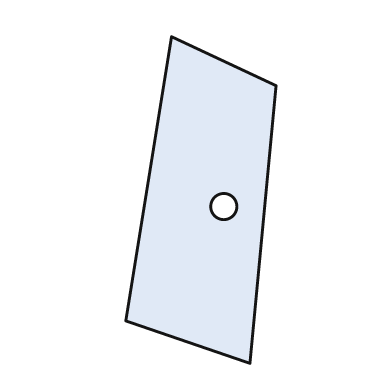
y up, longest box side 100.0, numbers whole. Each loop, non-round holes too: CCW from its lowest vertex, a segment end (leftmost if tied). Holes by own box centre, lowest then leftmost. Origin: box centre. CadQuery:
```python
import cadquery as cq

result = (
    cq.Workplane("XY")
    .moveTo(15.0, -50.0)
    .lineTo(23.0, 35.0)
    .lineTo(-9.0, 50.0)
    .lineTo(-23.0, -37.0)
    .close()
    .moveTo(7.0, -2.0)
    .circle(4.0)
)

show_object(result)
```